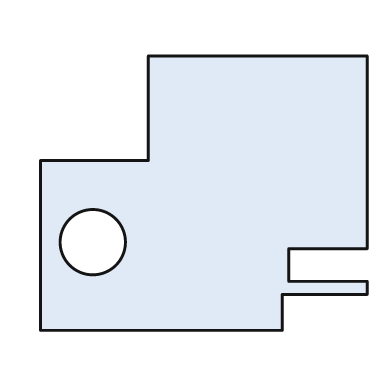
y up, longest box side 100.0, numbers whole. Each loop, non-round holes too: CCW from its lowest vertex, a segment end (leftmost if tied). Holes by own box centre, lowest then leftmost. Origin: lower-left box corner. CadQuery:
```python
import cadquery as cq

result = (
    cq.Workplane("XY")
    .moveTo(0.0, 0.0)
    .lineTo(74.0, 0.0)
    .lineTo(74.0, 11.0)
    .lineTo(100.0, 11.0)
    .lineTo(100.0, 15.0)
    .lineTo(76.0, 15.0)
    .lineTo(76.0, 25.0)
    .lineTo(100.0, 25.0)
    .lineTo(100.0, 84.0)
    .lineTo(33.0, 84.0)
    .lineTo(33.0, 52.0)
    .lineTo(0.0, 52.0)
    .close()
    .moveTo(16.0, 27.0)
    .circle(10.0)
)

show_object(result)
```